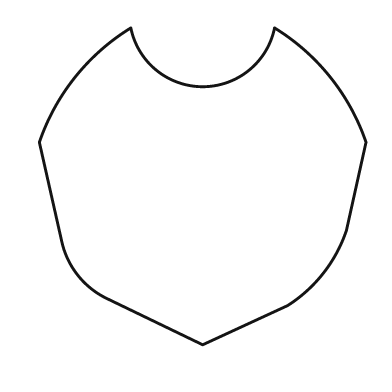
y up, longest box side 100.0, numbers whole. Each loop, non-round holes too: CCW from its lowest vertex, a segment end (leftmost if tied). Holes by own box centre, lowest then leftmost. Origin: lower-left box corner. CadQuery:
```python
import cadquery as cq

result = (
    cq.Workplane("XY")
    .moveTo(50.0, 0.0)
    .lineTo(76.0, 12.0)
    .threePointArc((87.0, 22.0), (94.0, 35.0))
    .lineTo(100.0, 62.0)
    .threePointArc((89.0, 82.0), (72.0, 97.0))
    .threePointArc((50.0, 79.0), (28.0, 97.0))
    .threePointArc((11.0, 82.0), (0.0, 62.0))
    .lineTo(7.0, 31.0)
    .threePointArc((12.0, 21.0), (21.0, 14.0))
    .close()
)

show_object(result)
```